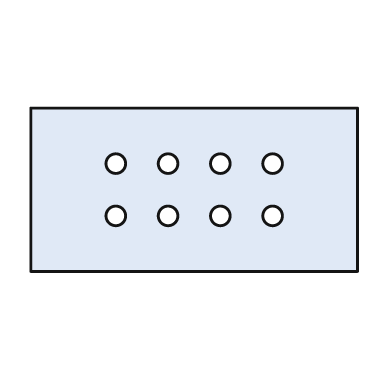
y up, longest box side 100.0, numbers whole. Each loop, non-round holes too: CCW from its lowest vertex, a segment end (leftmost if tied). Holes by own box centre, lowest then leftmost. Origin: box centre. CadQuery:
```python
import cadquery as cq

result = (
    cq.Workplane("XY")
    .moveTo(-50.0, -25.0)
    .lineTo(50.0, -25.0)
    .lineTo(50.0, 25.0)
    .lineTo(-50.0, 25.0)
    .close()
    .moveTo(-24.0, -8.0)
    .circle(3.0)
    .moveTo(-8.0, -8.0)
    .circle(3.0)
    .moveTo(8.0, -8.0)
    .circle(3.0)
    .moveTo(24.0, -8.0)
    .circle(3.0)
    .moveTo(-24.0, 8.0)
    .circle(3.0)
    .moveTo(-8.0, 8.0)
    .circle(3.0)
    .moveTo(8.0, 8.0)
    .circle(3.0)
    .moveTo(24.0, 8.0)
    .circle(3.0)
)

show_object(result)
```